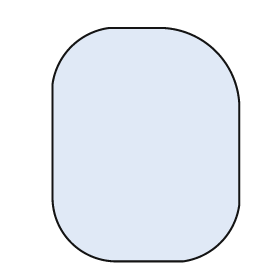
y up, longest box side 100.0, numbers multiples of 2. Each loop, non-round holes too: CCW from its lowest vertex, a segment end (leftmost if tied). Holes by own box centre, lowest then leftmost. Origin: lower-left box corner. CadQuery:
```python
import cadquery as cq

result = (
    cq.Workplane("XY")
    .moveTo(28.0, 0.0)
    .lineTo(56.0, 0.0)
    .threePointArc((72.0, 8.0), (80.0, 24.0))
    .lineTo(80.0, 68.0)
    .threePointArc((70.0, 90.0), (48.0, 100.0))
    .lineTo(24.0, 100.0)
    .threePointArc((8.0, 92.0), (0.0, 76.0))
    .lineTo(0.0, 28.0)
    .threePointArc((8.0, 8.0), (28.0, 0.0))
    .close()
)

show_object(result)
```